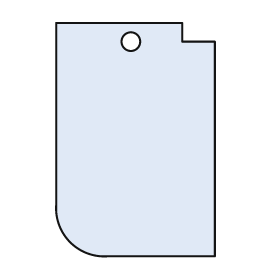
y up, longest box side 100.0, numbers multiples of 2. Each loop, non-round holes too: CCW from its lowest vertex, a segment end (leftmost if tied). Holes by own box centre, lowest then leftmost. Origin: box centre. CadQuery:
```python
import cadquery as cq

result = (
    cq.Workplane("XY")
    .moveTo(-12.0, -50.0)
    .lineTo(34.0, -50.0)
    .lineTo(34.0, 42.0)
    .lineTo(20.0, 42.0)
    .lineTo(20.0, 50.0)
    .lineTo(-34.0, 50.0)
    .lineTo(-34.0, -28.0)
    .threePointArc((-28.0, -44.0), (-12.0, -50.0))
    .close()
    .moveTo(-2.0, 42.0)
    .circle(4.0)
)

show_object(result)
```